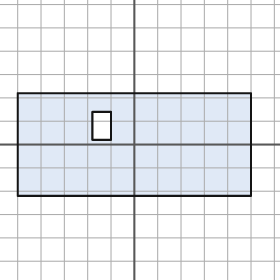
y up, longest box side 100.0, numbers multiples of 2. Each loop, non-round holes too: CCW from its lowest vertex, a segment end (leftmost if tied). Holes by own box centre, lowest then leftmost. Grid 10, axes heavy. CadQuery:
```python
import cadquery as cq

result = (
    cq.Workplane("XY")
    .moveTo(-50.0, -22.0)
    .lineTo(50.0, -22.0)
    .lineTo(50.0, 22.0)
    .lineTo(-50.0, 22.0)
    .close()
    .moveTo(-18.0, 2.0)
    .lineTo(-10.0, 2.0)
    .lineTo(-10.0, 14.0)
    .lineTo(-18.0, 14.0)
    .close()
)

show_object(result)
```